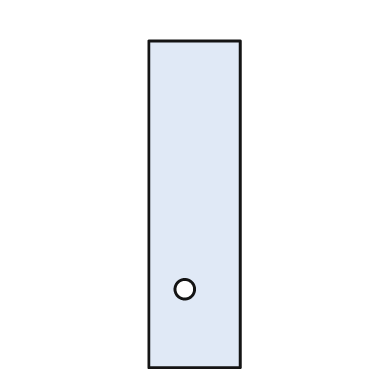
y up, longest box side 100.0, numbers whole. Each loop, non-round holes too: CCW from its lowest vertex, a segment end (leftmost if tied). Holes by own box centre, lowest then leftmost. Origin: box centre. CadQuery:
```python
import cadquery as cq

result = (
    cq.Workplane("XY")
    .moveTo(-14.0, -50.0)
    .lineTo(14.0, -50.0)
    .lineTo(14.0, 50.0)
    .lineTo(-14.0, 50.0)
    .close()
    .moveTo(-3.0, -26.0)
    .circle(3.0)
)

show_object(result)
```